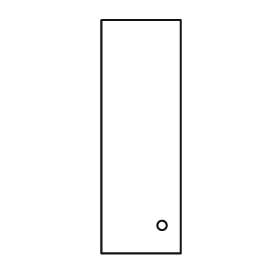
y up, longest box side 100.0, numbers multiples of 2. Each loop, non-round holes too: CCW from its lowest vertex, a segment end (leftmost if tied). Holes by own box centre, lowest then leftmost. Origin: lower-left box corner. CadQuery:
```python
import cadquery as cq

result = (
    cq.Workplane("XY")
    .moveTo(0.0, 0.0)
    .lineTo(34.0, 0.0)
    .lineTo(34.0, 100.0)
    .lineTo(0.0, 100.0)
    .close()
    .moveTo(26.0, 12.0)
    .circle(2.0)
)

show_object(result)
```